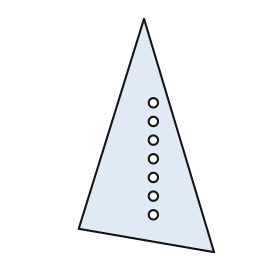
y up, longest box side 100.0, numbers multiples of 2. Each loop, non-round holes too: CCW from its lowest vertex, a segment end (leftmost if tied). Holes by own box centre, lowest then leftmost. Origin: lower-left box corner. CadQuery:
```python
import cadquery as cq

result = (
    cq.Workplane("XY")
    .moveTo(58.0, 0.0)
    .lineTo(28.0, 100.0)
    .lineTo(0.0, 10.0)
    .close()
    .moveTo(32.0, 16.0)
    .circle(2.0)
    .moveTo(32.0, 24.0)
    .circle(2.0)
    .moveTo(32.0, 32.0)
    .circle(2.0)
    .moveTo(32.0, 40.0)
    .circle(2.0)
    .moveTo(32.0, 48.0)
    .circle(2.0)
    .moveTo(32.0, 56.0)
    .circle(2.0)
    .moveTo(32.0, 64.0)
    .circle(2.0)
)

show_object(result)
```